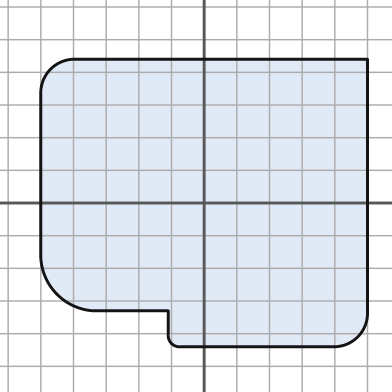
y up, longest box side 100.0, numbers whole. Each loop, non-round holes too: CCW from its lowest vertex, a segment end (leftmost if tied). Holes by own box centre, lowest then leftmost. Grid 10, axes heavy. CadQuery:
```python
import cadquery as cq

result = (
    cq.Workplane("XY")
    .moveTo(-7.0, -44.0)
    .lineTo(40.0, -44.0)
    .threePointArc((47.0, -41.0), (50.0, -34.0))
    .lineTo(50.0, 44.0)
    .lineTo(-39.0, 44.0)
    .threePointArc((-47.0, 41.0), (-50.0, 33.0))
    .lineTo(-50.0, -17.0)
    .threePointArc((-45.0, -28.0), (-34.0, -33.0))
    .lineTo(-11.0, -33.0)
    .lineTo(-11.0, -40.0)
    .threePointArc((-10.0, -43.0), (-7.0, -44.0))
    .close()
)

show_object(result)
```